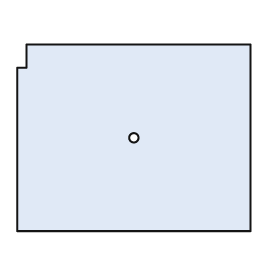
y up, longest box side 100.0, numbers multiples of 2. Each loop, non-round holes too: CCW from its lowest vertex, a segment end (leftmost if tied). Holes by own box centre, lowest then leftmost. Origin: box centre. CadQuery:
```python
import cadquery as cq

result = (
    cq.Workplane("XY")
    .moveTo(-50.0, -40.0)
    .lineTo(50.0, -40.0)
    .lineTo(50.0, 40.0)
    .lineTo(-46.0, 40.0)
    .lineTo(-46.0, 30.0)
    .lineTo(-50.0, 30.0)
    .close()
    .moveTo(0.0, 0.0)
    .circle(2.0)
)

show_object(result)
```